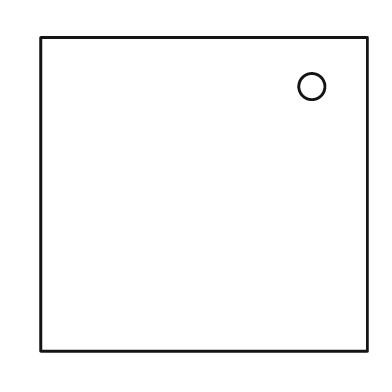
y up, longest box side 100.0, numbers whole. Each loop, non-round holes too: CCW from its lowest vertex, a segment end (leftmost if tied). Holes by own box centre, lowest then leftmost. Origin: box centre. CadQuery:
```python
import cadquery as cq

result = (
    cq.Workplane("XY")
    .moveTo(-50.0, -48.0)
    .lineTo(50.0, -48.0)
    .lineTo(50.0, 48.0)
    .lineTo(-50.0, 48.0)
    .close()
    .moveTo(33.0, 33.0)
    .circle(4.0)
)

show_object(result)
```